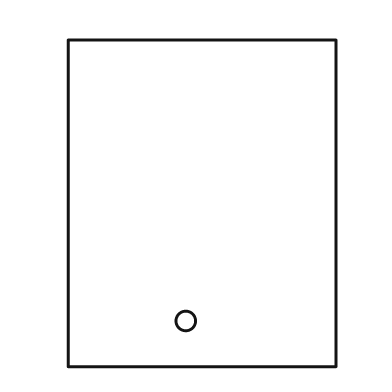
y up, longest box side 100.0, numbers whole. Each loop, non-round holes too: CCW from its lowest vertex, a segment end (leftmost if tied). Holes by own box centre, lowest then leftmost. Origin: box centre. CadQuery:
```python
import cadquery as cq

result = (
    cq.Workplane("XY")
    .moveTo(-41.0, -50.0)
    .lineTo(41.0, -50.0)
    .lineTo(41.0, 50.0)
    .lineTo(-41.0, 50.0)
    .close()
    .moveTo(-5.0, -36.0)
    .circle(3.0)
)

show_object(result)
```